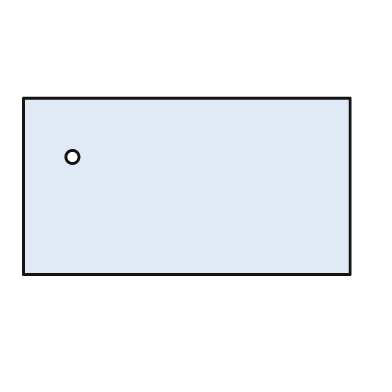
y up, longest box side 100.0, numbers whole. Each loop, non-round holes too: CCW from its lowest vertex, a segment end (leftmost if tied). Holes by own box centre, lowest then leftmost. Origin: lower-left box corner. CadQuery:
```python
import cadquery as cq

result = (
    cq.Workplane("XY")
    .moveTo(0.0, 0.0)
    .lineTo(100.0, 0.0)
    .lineTo(100.0, 54.0)
    .lineTo(0.0, 54.0)
    .close()
    .moveTo(15.0, 36.0)
    .circle(2.0)
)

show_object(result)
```